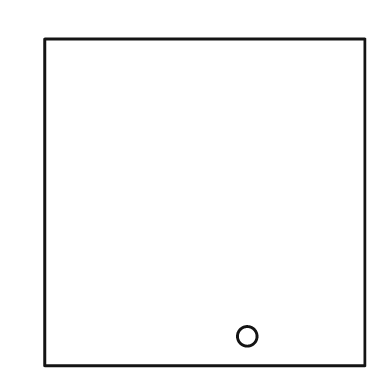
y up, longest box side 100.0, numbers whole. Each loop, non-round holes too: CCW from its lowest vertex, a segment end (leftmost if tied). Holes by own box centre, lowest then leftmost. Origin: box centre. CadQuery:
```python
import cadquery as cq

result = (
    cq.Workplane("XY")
    .moveTo(-49.0, -50.0)
    .lineTo(49.0, -50.0)
    .lineTo(49.0, 50.0)
    .lineTo(-49.0, 50.0)
    .close()
    .moveTo(13.0, -41.0)
    .circle(3.0)
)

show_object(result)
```